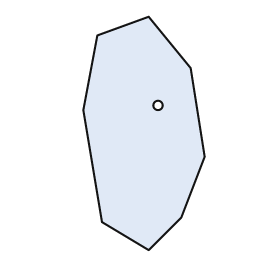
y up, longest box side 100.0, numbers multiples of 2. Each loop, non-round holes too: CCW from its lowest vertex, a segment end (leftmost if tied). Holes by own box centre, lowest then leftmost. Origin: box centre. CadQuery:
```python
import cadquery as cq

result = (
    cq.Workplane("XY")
    .moveTo(2.0, -50.0)
    .lineTo(16.0, -36.0)
    .lineTo(26.0, -10.0)
    .lineTo(20.0, 28.0)
    .lineTo(2.0, 50.0)
    .lineTo(-20.0, 42.0)
    .lineTo(-26.0, 10.0)
    .lineTo(-18.0, -38.0)
    .close()
    .moveTo(6.0, 12.0)
    .circle(2.0)
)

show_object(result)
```